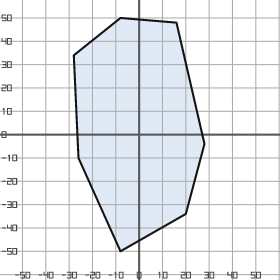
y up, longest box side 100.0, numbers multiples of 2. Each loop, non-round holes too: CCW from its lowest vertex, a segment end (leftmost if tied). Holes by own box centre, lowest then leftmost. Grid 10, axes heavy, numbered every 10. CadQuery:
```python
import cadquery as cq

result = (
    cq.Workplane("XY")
    .moveTo(-8.0, -50.0)
    .lineTo(20.0, -34.0)
    .lineTo(28.0, -4.0)
    .lineTo(16.0, 48.0)
    .lineTo(-8.0, 50.0)
    .lineTo(-28.0, 34.0)
    .lineTo(-26.0, -10.0)
    .close()
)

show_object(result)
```